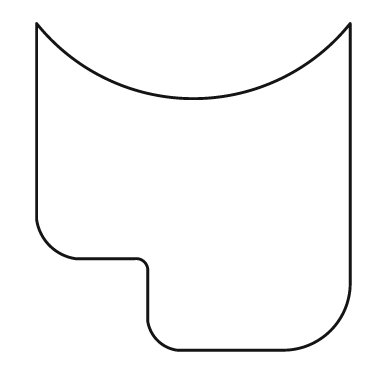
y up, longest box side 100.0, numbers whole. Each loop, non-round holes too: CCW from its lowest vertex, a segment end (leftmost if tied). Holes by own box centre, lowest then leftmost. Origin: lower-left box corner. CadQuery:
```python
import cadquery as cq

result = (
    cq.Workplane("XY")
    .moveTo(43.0, 0.0)
    .lineTo(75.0, 0.0)
    .threePointArc((90.0, 6.0), (96.0, 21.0))
    .lineTo(96.0, 100.0)
    .threePointArc((48.0, 77.0), (0.0, 100.0))
    .lineTo(0.0, 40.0)
    .threePointArc((4.0, 32.0), (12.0, 28.0))
    .lineTo(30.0, 28.0)
    .threePointArc((33.0, 27.0), (34.0, 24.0))
    .lineTo(34.0, 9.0)
    .threePointArc((37.0, 3.0), (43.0, 0.0))
    .close()
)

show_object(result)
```